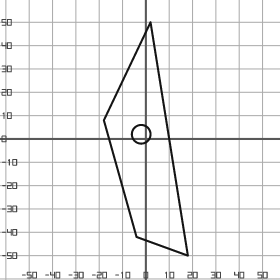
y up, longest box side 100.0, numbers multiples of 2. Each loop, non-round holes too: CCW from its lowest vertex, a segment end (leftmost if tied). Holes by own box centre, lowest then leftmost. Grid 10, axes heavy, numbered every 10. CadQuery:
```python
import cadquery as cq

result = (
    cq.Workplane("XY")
    .moveTo(18.0, -50.0)
    .lineTo(2.0, 50.0)
    .lineTo(-18.0, 8.0)
    .lineTo(-4.0, -42.0)
    .close()
    .moveTo(-2.0, 2.0)
    .circle(4.0)
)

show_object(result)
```